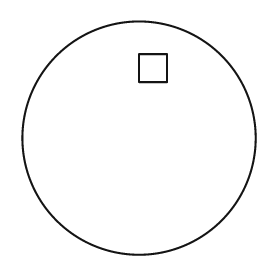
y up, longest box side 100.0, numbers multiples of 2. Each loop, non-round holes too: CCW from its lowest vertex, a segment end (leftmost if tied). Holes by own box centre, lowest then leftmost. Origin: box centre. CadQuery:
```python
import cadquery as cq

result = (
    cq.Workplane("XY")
    .moveTo(0.0, 0.0)
    .circle(50.0)
    .moveTo(0.0, 24.0)
    .lineTo(12.0, 24.0)
    .lineTo(12.0, 36.0)
    .lineTo(0.0, 36.0)
    .close()
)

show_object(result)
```